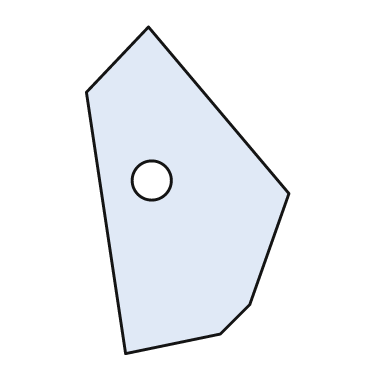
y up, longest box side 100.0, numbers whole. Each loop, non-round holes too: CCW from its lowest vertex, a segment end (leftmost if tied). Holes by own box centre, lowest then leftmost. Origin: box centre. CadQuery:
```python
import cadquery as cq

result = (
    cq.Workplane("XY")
    .moveTo(-19.0, -50.0)
    .lineTo(10.0, -44.0)
    .lineTo(19.0, -35.0)
    .lineTo(31.0, -1.0)
    .lineTo(-12.0, 50.0)
    .lineTo(-31.0, 30.0)
    .close()
    .moveTo(-11.0, 3.0)
    .circle(6.0)
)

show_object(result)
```